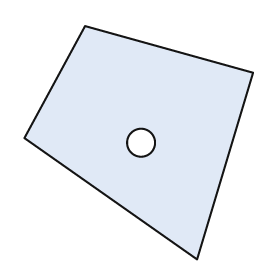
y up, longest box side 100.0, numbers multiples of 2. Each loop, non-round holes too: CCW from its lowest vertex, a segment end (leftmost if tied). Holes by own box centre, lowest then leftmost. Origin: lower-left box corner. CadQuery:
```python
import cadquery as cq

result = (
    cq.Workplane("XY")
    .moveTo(74.0, 0.0)
    .lineTo(98.0, 80.0)
    .lineTo(26.0, 100.0)
    .lineTo(0.0, 52.0)
    .close()
    .moveTo(50.0, 50.0)
    .circle(6.0)
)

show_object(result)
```